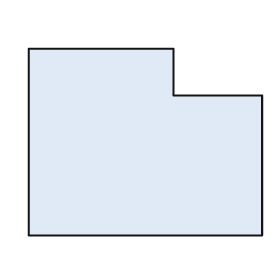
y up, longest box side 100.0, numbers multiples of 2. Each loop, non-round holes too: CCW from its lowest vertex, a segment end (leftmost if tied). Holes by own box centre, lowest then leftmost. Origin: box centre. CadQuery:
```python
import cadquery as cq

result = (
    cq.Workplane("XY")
    .moveTo(-50.0, -40.0)
    .lineTo(50.0, -40.0)
    .lineTo(50.0, 20.0)
    .lineTo(12.0, 20.0)
    .lineTo(12.0, 40.0)
    .lineTo(-50.0, 40.0)
    .close()
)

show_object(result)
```